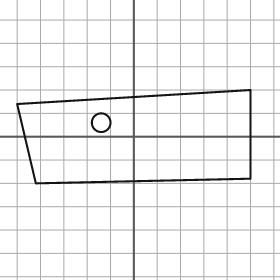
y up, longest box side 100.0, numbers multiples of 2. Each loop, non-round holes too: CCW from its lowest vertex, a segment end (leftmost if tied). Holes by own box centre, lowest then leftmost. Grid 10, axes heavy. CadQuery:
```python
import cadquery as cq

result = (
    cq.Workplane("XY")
    .moveTo(-42.0, -20.0)
    .lineTo(50.0, -18.0)
    .lineTo(50.0, 20.0)
    .lineTo(-50.0, 14.0)
    .close()
    .moveTo(-14.0, 6.0)
    .circle(4.0)
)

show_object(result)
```